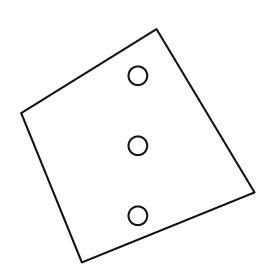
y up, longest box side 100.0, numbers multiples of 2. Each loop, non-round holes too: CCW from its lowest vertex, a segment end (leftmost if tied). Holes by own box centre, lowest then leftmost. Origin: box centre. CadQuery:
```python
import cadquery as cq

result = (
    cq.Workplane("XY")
    .moveTo(-24.0, -50.0)
    .lineTo(50.0, -20.0)
    .lineTo(8.0, 50.0)
    .lineTo(-50.0, 14.0)
    .close()
    .moveTo(0.0, -30.0)
    .circle(4.0)
    .moveTo(0.0, 0.0)
    .circle(4.0)
    .moveTo(0.0, 30.0)
    .circle(4.0)
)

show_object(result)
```